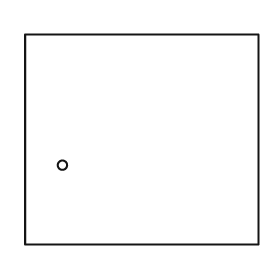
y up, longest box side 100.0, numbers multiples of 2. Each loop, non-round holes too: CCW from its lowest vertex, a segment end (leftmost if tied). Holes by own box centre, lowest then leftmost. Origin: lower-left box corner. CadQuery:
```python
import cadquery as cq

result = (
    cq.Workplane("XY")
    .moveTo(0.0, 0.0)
    .lineTo(100.0, 0.0)
    .lineTo(100.0, 90.0)
    .lineTo(0.0, 90.0)
    .close()
    .moveTo(16.0, 34.0)
    .circle(2.0)
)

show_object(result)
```